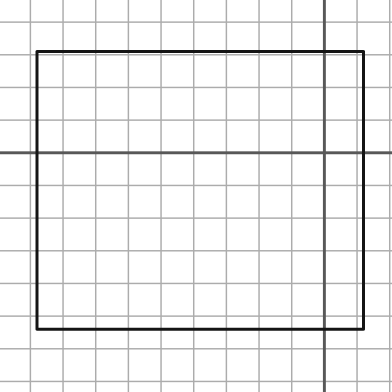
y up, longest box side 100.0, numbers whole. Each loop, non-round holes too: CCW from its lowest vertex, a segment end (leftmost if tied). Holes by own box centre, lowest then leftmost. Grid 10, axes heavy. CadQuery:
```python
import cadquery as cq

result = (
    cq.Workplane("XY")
    .moveTo(-88.0, -54.0)
    .lineTo(12.0, -54.0)
    .lineTo(12.0, 31.0)
    .lineTo(-88.0, 31.0)
    .close()
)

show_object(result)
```